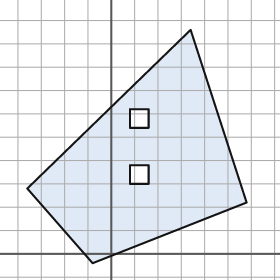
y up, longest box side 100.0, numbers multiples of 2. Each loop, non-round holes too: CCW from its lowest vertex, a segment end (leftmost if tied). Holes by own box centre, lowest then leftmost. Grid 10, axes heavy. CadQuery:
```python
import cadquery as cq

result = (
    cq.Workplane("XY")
    .moveTo(-8.0, -4.0)
    .lineTo(58.0, 22.0)
    .lineTo(34.0, 96.0)
    .lineTo(-36.0, 28.0)
    .close()
    .moveTo(8.0, 30.0)
    .lineTo(16.0, 30.0)
    .lineTo(16.0, 38.0)
    .lineTo(8.0, 38.0)
    .close()
    .moveTo(8.0, 54.0)
    .lineTo(16.0, 54.0)
    .lineTo(16.0, 62.0)
    .lineTo(8.0, 62.0)
    .close()
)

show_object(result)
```